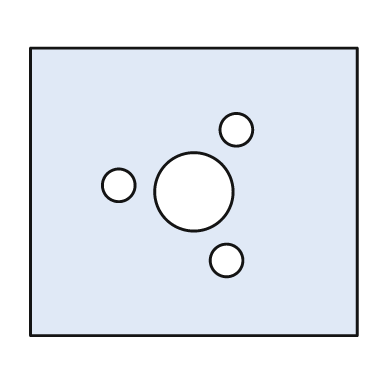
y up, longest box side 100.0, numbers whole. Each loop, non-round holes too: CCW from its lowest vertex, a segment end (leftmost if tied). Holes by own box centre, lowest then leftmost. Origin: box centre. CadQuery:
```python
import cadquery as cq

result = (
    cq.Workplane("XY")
    .moveTo(-50.0, -44.0)
    .lineTo(50.0, -44.0)
    .lineTo(50.0, 44.0)
    .lineTo(-50.0, 44.0)
    .close()
    .moveTo(10.0, -21.0)
    .circle(5.0)
    .moveTo(0.0, 0.0)
    .circle(12.0)
    .moveTo(-23.0, 2.0)
    .circle(5.0)
    .moveTo(13.0, 19.0)
    .circle(5.0)
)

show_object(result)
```